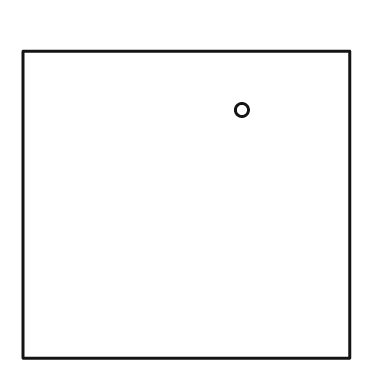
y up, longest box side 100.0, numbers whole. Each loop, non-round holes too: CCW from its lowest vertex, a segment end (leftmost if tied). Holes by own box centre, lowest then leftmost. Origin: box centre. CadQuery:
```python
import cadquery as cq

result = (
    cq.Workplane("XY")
    .moveTo(-50.0, -47.0)
    .lineTo(50.0, -47.0)
    .lineTo(50.0, 47.0)
    .lineTo(-50.0, 47.0)
    .close()
    .moveTo(17.0, 29.0)
    .circle(2.0)
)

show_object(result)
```